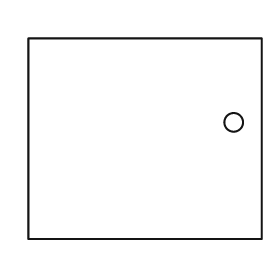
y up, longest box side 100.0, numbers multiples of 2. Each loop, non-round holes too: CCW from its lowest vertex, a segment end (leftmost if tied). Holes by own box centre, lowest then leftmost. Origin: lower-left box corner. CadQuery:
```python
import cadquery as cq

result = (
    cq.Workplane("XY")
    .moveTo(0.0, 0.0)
    .lineTo(100.0, 0.0)
    .lineTo(100.0, 86.0)
    .lineTo(0.0, 86.0)
    .close()
    .moveTo(88.0, 50.0)
    .circle(4.0)
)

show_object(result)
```